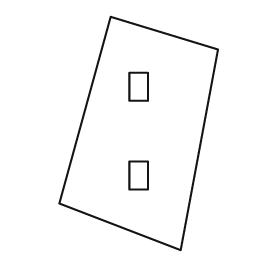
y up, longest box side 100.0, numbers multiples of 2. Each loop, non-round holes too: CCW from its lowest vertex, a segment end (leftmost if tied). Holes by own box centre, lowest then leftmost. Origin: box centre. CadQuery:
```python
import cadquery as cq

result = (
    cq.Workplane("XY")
    .moveTo(18.0, -50.0)
    .lineTo(34.0, 36.0)
    .lineTo(-12.0, 50.0)
    .lineTo(-34.0, -30.0)
    .close()
    .moveTo(-4.0, -24.0)
    .lineTo(4.0, -24.0)
    .lineTo(4.0, -12.0)
    .lineTo(-4.0, -12.0)
    .close()
    .moveTo(-4.0, 14.0)
    .lineTo(4.0, 14.0)
    .lineTo(4.0, 26.0)
    .lineTo(-4.0, 26.0)
    .close()
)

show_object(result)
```